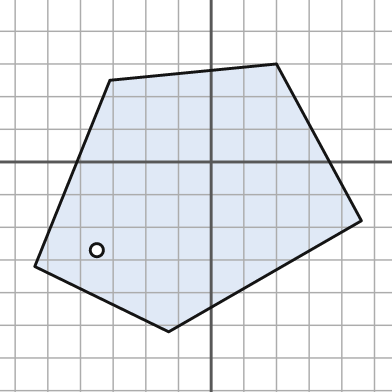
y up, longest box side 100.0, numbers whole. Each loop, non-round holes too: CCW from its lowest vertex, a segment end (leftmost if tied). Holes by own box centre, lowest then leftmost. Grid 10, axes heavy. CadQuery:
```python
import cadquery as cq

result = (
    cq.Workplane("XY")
    .moveTo(-13.0, -52.0)
    .lineTo(46.0, -18.0)
    .lineTo(20.0, 30.0)
    .lineTo(-31.0, 25.0)
    .lineTo(-54.0, -32.0)
    .close()
    .moveTo(-35.0, -27.0)
    .circle(2.0)
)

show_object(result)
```